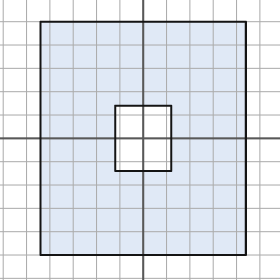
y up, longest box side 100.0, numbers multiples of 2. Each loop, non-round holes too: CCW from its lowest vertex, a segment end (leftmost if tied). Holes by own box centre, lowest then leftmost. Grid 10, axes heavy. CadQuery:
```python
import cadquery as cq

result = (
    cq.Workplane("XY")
    .moveTo(-44.0, -50.0)
    .lineTo(44.0, -50.0)
    .lineTo(44.0, 50.0)
    .lineTo(-44.0, 50.0)
    .close()
    .moveTo(-12.0, -14.0)
    .lineTo(12.0, -14.0)
    .lineTo(12.0, 14.0)
    .lineTo(-12.0, 14.0)
    .close()
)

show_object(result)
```